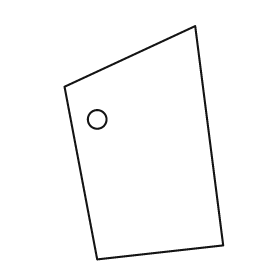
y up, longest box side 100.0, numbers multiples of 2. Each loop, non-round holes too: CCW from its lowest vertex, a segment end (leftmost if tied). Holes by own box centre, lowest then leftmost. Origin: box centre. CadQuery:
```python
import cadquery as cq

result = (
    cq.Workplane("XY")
    .moveTo(-20.0, -50.0)
    .lineTo(34.0, -44.0)
    .lineTo(22.0, 50.0)
    .lineTo(-34.0, 24.0)
    .close()
    .moveTo(-20.0, 10.0)
    .circle(4.0)
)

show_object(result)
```